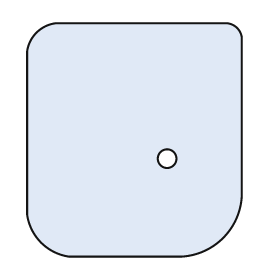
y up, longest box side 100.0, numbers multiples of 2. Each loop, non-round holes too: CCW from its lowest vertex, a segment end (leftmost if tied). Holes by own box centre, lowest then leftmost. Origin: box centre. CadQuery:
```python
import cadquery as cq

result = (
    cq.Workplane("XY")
    .moveTo(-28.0, -50.0)
    .lineTo(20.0, -50.0)
    .threePointArc((38.0, -42.0), (46.0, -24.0))
    .lineTo(46.0, 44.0)
    .threePointArc((44.0, 48.0), (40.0, 50.0))
    .lineTo(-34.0, 50.0)
    .threePointArc((-42.0, 46.0), (-46.0, 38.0))
    .lineTo(-46.0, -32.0)
    .threePointArc((-40.0, -44.0), (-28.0, -50.0))
    .close()
    .moveTo(14.0, -8.0)
    .circle(4.0)
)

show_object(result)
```